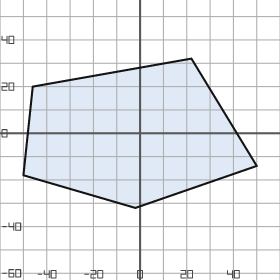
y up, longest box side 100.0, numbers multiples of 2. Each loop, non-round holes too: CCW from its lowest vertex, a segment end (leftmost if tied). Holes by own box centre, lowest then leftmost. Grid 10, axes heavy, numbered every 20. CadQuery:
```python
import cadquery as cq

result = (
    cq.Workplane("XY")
    .moveTo(-2.0, -32.0)
    .lineTo(50.0, -14.0)
    .lineTo(22.0, 32.0)
    .lineTo(-46.0, 20.0)
    .lineTo(-50.0, -18.0)
    .close()
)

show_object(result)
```